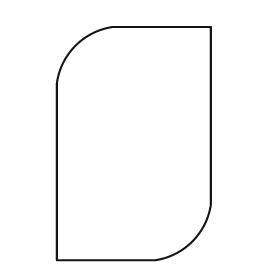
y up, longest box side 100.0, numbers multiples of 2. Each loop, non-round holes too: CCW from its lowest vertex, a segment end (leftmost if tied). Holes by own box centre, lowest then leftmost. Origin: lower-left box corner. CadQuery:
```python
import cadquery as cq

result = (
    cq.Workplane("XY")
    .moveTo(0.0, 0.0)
    .lineTo(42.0, 0.0)
    .threePointArc((58.0, 8.0), (66.0, 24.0))
    .lineTo(66.0, 100.0)
    .lineTo(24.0, 100.0)
    .threePointArc((8.0, 92.0), (0.0, 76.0))
    .close()
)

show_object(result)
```